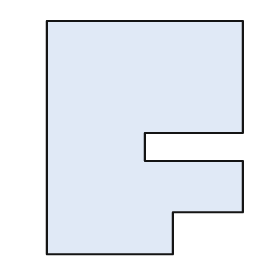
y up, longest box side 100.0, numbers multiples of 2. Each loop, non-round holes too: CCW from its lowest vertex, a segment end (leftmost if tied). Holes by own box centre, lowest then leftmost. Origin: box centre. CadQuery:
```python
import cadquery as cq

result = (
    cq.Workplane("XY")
    .moveTo(-42.0, -50.0)
    .lineTo(12.0, -50.0)
    .lineTo(12.0, -32.0)
    .lineTo(42.0, -32.0)
    .lineTo(42.0, -10.0)
    .lineTo(0.0, -10.0)
    .lineTo(0.0, 2.0)
    .lineTo(42.0, 2.0)
    .lineTo(42.0, 50.0)
    .lineTo(-42.0, 50.0)
    .close()
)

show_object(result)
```